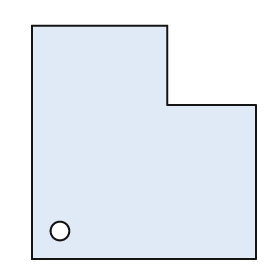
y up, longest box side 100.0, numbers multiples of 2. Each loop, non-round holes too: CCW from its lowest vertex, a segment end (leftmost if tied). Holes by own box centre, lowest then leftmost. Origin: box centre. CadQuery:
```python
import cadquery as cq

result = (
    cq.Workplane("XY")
    .moveTo(-48.0, -50.0)
    .lineTo(48.0, -50.0)
    .lineTo(48.0, 16.0)
    .lineTo(10.0, 16.0)
    .lineTo(10.0, 50.0)
    .lineTo(-48.0, 50.0)
    .close()
    .moveTo(-36.0, -38.0)
    .circle(4.0)
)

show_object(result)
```